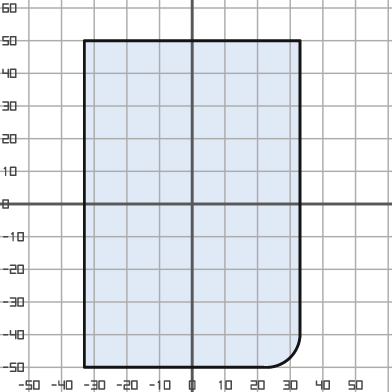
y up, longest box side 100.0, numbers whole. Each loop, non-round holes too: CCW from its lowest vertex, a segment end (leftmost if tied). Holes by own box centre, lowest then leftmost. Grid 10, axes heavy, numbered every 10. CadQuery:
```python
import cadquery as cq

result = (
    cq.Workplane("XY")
    .moveTo(-33.0, -50.0)
    .lineTo(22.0, -50.0)
    .threePointArc((30.0, -47.0), (33.0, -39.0))
    .lineTo(33.0, 50.0)
    .lineTo(-33.0, 50.0)
    .close()
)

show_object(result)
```